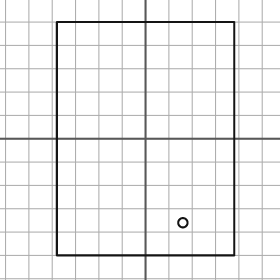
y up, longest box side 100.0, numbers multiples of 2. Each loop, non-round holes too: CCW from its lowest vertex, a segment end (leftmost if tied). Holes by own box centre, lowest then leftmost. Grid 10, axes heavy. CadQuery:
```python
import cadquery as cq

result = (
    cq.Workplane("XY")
    .moveTo(-38.0, -50.0)
    .lineTo(38.0, -50.0)
    .lineTo(38.0, 50.0)
    .lineTo(-38.0, 50.0)
    .close()
    .moveTo(16.0, -36.0)
    .circle(2.0)
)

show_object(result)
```